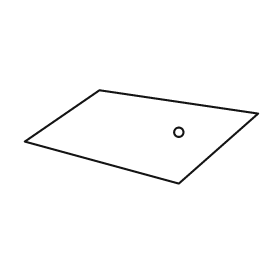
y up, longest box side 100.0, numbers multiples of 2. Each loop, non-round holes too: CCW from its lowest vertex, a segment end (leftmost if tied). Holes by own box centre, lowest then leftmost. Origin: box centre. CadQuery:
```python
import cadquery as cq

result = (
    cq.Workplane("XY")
    .moveTo(16.0, -20.0)
    .lineTo(50.0, 10.0)
    .lineTo(-18.0, 20.0)
    .lineTo(-50.0, -2.0)
    .close()
    .moveTo(16.0, 2.0)
    .circle(2.0)
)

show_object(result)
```